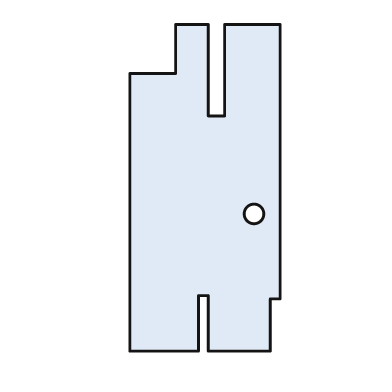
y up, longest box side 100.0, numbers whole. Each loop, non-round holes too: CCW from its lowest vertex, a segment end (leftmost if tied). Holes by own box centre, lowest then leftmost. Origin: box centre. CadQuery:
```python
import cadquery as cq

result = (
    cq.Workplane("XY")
    .moveTo(-23.0, -50.0)
    .lineTo(-2.0, -50.0)
    .lineTo(-2.0, -33.0)
    .lineTo(1.0, -33.0)
    .lineTo(1.0, -50.0)
    .lineTo(20.0, -50.0)
    .lineTo(20.0, -34.0)
    .lineTo(23.0, -34.0)
    .lineTo(23.0, 50.0)
    .lineTo(6.0, 50.0)
    .lineTo(6.0, 22.0)
    .lineTo(1.0, 22.0)
    .lineTo(1.0, 50.0)
    .lineTo(-9.0, 50.0)
    .lineTo(-9.0, 35.0)
    .lineTo(-23.0, 35.0)
    .close()
    .moveTo(15.0, -8.0)
    .circle(3.0)
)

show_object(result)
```